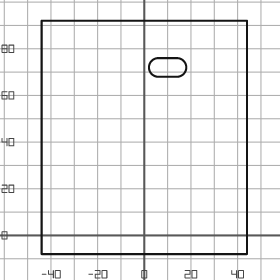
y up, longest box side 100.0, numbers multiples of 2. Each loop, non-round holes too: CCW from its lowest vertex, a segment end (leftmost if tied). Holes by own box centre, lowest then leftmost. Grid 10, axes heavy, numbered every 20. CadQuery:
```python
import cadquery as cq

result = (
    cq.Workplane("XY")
    .moveTo(-44.0, -8.0)
    .lineTo(44.0, -8.0)
    .lineTo(44.0, 92.0)
    .lineTo(-44.0, 92.0)
    .close()
    .moveTo(6.0, 68.0)
    .lineTo(14.0, 68.0)
    .threePointArc((18.0, 72.0), (14.0, 76.0))
    .lineTo(6.0, 76.0)
    .threePointArc((2.0, 72.0), (6.0, 68.0))
    .close()
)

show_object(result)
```